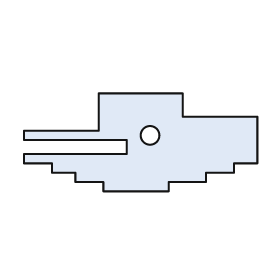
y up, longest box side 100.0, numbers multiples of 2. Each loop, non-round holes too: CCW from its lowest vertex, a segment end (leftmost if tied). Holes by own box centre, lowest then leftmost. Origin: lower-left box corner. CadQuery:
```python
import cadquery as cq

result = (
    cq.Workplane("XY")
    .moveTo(34.0, 0.0)
    .lineTo(62.0, 0.0)
    .lineTo(62.0, 4.0)
    .lineTo(78.0, 4.0)
    .lineTo(78.0, 8.0)
    .lineTo(90.0, 8.0)
    .lineTo(90.0, 12.0)
    .lineTo(100.0, 12.0)
    .lineTo(100.0, 32.0)
    .lineTo(68.0, 32.0)
    .lineTo(68.0, 42.0)
    .lineTo(32.0, 42.0)
    .lineTo(32.0, 26.0)
    .lineTo(0.0, 26.0)
    .lineTo(0.0, 22.0)
    .lineTo(44.0, 22.0)
    .lineTo(44.0, 16.0)
    .lineTo(0.0, 16.0)
    .lineTo(0.0, 12.0)
    .lineTo(12.0, 12.0)
    .lineTo(12.0, 8.0)
    .lineTo(22.0, 8.0)
    .lineTo(22.0, 4.0)
    .lineTo(34.0, 4.0)
    .close()
    .moveTo(54.0, 24.0)
    .circle(4.0)
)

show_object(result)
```